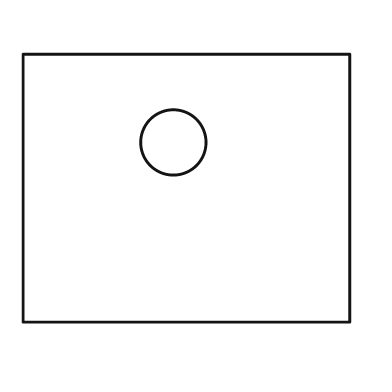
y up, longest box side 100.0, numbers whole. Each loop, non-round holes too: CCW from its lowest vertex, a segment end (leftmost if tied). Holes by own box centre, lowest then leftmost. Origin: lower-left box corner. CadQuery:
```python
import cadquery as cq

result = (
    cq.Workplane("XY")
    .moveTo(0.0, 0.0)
    .lineTo(100.0, 0.0)
    .lineTo(100.0, 82.0)
    .lineTo(0.0, 82.0)
    .close()
    .moveTo(46.0, 55.0)
    .circle(10.0)
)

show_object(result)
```